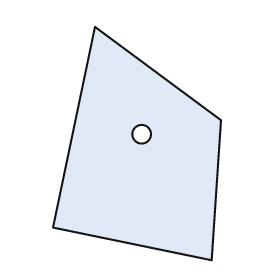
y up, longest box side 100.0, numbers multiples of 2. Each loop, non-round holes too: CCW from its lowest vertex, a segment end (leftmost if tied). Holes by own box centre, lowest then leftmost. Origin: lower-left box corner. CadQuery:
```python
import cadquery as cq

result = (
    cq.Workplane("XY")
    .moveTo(68.0, 0.0)
    .lineTo(72.0, 60.0)
    .lineTo(18.0, 100.0)
    .lineTo(0.0, 14.0)
    .close()
    .moveTo(38.0, 54.0)
    .circle(4.0)
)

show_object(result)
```